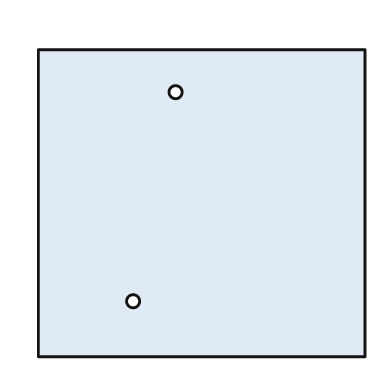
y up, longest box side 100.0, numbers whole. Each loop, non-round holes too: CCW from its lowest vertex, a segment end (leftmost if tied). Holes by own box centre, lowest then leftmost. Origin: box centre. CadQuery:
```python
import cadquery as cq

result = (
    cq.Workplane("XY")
    .moveTo(-50.0, -47.0)
    .lineTo(50.0, -47.0)
    .lineTo(50.0, 47.0)
    .lineTo(-50.0, 47.0)
    .close()
    .moveTo(-21.0, -30.0)
    .circle(2.0)
    .moveTo(-8.0, 34.0)
    .circle(2.0)
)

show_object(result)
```